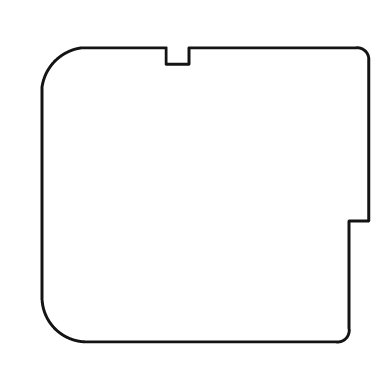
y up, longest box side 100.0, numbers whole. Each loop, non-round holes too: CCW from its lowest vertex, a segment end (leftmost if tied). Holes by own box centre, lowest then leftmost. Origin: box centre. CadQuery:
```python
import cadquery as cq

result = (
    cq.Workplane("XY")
    .moveTo(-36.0, -45.0)
    .lineTo(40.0, -45.0)
    .threePointArc((43.0, -44.0), (44.0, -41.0))
    .lineTo(44.0, -8.0)
    .lineTo(50.0, -8.0)
    .lineTo(50.0, 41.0)
    .threePointArc((49.0, 44.0), (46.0, 45.0))
    .lineTo(-5.0, 45.0)
    .lineTo(-5.0, 40.0)
    .lineTo(-12.0, 40.0)
    .lineTo(-12.0, 45.0)
    .lineTo(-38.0, 45.0)
    .threePointArc((-46.0, 41.0), (-50.0, 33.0))
    .lineTo(-50.0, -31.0)
    .threePointArc((-46.0, -41.0), (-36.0, -45.0))
    .close()
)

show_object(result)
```